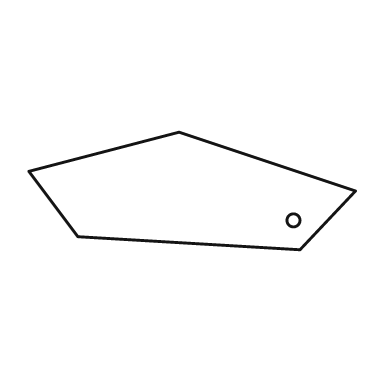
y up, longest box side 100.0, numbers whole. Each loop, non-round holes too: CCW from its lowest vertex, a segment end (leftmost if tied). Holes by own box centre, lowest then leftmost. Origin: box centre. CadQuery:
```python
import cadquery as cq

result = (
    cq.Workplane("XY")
    .moveTo(33.0, -18.0)
    .lineTo(50.0, 0.0)
    .lineTo(-4.0, 18.0)
    .lineTo(-50.0, 6.0)
    .lineTo(-35.0, -14.0)
    .close()
    .moveTo(31.0, -9.0)
    .circle(2.0)
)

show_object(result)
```